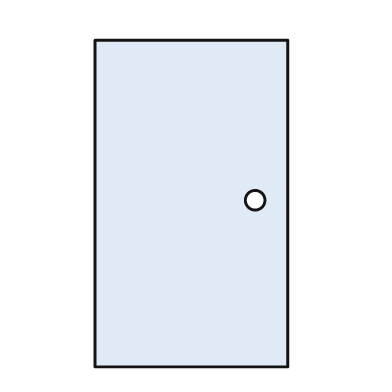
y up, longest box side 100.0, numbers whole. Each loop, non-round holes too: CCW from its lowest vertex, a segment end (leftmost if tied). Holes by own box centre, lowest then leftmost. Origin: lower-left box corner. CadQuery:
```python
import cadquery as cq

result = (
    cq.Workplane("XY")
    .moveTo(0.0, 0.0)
    .lineTo(59.0, 0.0)
    .lineTo(59.0, 100.0)
    .lineTo(0.0, 100.0)
    .close()
    .moveTo(49.0, 51.0)
    .circle(3.0)
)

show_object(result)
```